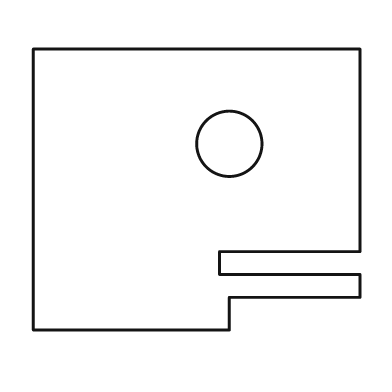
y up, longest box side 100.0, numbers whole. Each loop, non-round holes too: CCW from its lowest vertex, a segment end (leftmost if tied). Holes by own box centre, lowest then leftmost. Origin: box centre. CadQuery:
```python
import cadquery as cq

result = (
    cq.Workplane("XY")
    .moveTo(-50.0, -43.0)
    .lineTo(10.0, -43.0)
    .lineTo(10.0, -33.0)
    .lineTo(50.0, -33.0)
    .lineTo(50.0, -26.0)
    .lineTo(7.0, -26.0)
    .lineTo(7.0, -19.0)
    .lineTo(50.0, -19.0)
    .lineTo(50.0, 43.0)
    .lineTo(-50.0, 43.0)
    .close()
    .moveTo(10.0, 14.0)
    .circle(10.0)
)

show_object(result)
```